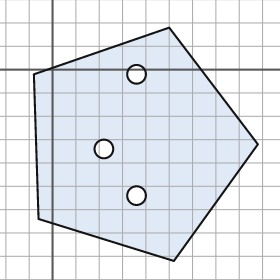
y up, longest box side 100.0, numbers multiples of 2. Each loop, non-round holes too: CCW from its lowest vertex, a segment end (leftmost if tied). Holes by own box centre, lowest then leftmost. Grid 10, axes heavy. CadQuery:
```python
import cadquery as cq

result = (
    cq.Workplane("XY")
    .moveTo(52.0, -82.0)
    .lineTo(88.0, -32.0)
    .lineTo(50.0, 18.0)
    .lineTo(-8.0, -2.0)
    .lineTo(-6.0, -64.0)
    .close()
    .moveTo(36.0, -54.0)
    .circle(4.0)
    .moveTo(22.0, -34.0)
    .circle(4.0)
    .moveTo(36.0, -2.0)
    .circle(4.0)
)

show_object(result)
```